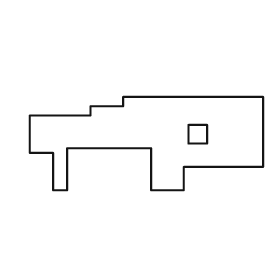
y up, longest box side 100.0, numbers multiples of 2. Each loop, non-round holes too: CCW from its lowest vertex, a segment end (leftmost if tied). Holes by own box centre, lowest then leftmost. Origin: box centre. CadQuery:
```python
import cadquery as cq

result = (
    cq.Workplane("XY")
    .moveTo(-40.0, -20.0)
    .lineTo(-34.0, -20.0)
    .lineTo(-34.0, -2.0)
    .lineTo(2.0, -2.0)
    .lineTo(2.0, -20.0)
    .lineTo(16.0, -20.0)
    .lineTo(16.0, -10.0)
    .lineTo(50.0, -10.0)
    .lineTo(50.0, 20.0)
    .lineTo(-10.0, 20.0)
    .lineTo(-10.0, 16.0)
    .lineTo(-24.0, 16.0)
    .lineTo(-24.0, 12.0)
    .lineTo(-50.0, 12.0)
    .lineTo(-50.0, -4.0)
    .lineTo(-40.0, -4.0)
    .close()
    .moveTo(18.0, 0.0)
    .lineTo(26.0, 0.0)
    .lineTo(26.0, 8.0)
    .lineTo(18.0, 8.0)
    .close()
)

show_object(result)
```